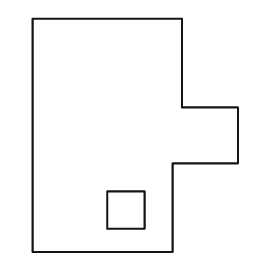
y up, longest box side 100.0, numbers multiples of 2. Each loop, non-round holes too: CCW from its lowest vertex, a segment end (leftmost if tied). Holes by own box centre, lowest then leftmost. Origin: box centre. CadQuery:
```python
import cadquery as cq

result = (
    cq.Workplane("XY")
    .moveTo(-44.0, -50.0)
    .lineTo(16.0, -50.0)
    .lineTo(16.0, -12.0)
    .lineTo(44.0, -12.0)
    .lineTo(44.0, 12.0)
    .lineTo(20.0, 12.0)
    .lineTo(20.0, 50.0)
    .lineTo(-44.0, 50.0)
    .close()
    .moveTo(-12.0, -40.0)
    .lineTo(4.0, -40.0)
    .lineTo(4.0, -24.0)
    .lineTo(-12.0, -24.0)
    .close()
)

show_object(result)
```